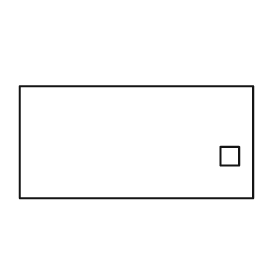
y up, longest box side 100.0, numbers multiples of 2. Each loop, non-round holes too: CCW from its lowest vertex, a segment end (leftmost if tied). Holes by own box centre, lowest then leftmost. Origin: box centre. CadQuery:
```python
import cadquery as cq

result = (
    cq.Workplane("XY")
    .moveTo(-50.0, -24.0)
    .lineTo(50.0, -24.0)
    .lineTo(50.0, 24.0)
    .lineTo(-50.0, 24.0)
    .close()
    .moveTo(36.0, -10.0)
    .lineTo(44.0, -10.0)
    .lineTo(44.0, -2.0)
    .lineTo(36.0, -2.0)
    .close()
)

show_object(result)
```